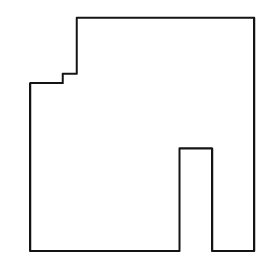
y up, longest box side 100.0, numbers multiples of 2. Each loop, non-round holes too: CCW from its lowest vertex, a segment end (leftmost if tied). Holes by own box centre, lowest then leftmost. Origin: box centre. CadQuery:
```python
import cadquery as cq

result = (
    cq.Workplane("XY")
    .moveTo(-48.0, -50.0)
    .lineTo(16.0, -50.0)
    .lineTo(16.0, -6.0)
    .lineTo(30.0, -6.0)
    .lineTo(30.0, -50.0)
    .lineTo(48.0, -50.0)
    .lineTo(48.0, 50.0)
    .lineTo(-28.0, 50.0)
    .lineTo(-28.0, 26.0)
    .lineTo(-34.0, 26.0)
    .lineTo(-34.0, 22.0)
    .lineTo(-48.0, 22.0)
    .close()
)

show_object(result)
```